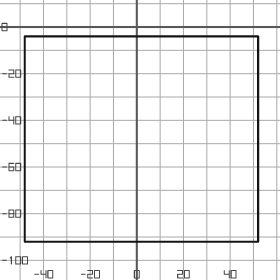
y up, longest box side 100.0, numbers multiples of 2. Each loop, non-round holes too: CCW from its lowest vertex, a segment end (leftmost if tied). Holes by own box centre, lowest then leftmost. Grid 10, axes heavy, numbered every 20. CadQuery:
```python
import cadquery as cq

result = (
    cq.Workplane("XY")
    .moveTo(-48.0, -92.0)
    .lineTo(52.0, -92.0)
    .lineTo(52.0, -4.0)
    .lineTo(-48.0, -4.0)
    .close()
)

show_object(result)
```